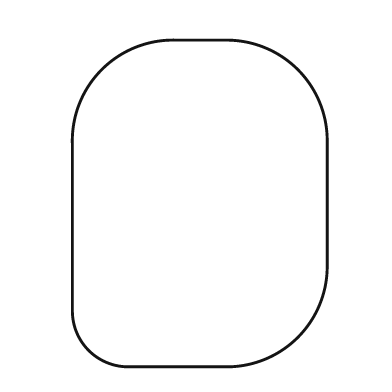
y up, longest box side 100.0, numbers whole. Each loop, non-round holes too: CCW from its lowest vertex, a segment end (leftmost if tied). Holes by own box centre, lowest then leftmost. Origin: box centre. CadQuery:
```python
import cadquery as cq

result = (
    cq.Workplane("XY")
    .moveTo(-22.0, -50.0)
    .lineTo(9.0, -50.0)
    .threePointArc((30.0, -41.0), (39.0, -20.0))
    .lineTo(39.0, 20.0)
    .threePointArc((30.0, 41.0), (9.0, 50.0))
    .lineTo(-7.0, 50.0)
    .threePointArc((-30.0, 41.0), (-39.0, 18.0))
    .lineTo(-39.0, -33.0)
    .threePointArc((-34.0, -45.0), (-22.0, -50.0))
    .close()
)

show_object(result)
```